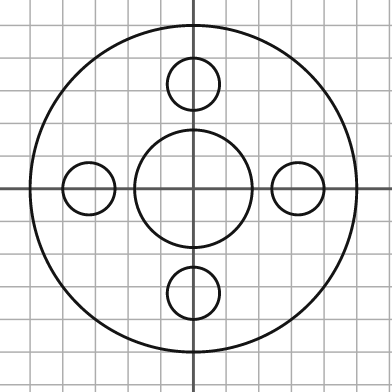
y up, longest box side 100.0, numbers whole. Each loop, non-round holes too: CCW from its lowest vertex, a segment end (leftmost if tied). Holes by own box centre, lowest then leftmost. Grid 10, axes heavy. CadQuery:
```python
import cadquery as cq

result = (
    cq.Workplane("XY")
    .moveTo(0.0, 0.0)
    .circle(50.0)
    .moveTo(0.0, -32.0)
    .circle(8.0)
    .moveTo(-32.0, 0.0)
    .circle(8.0)
    .moveTo(0.0, 0.0)
    .circle(18.0)
    .moveTo(32.0, 0.0)
    .circle(8.0)
    .moveTo(0.0, 32.0)
    .circle(8.0)
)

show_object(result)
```